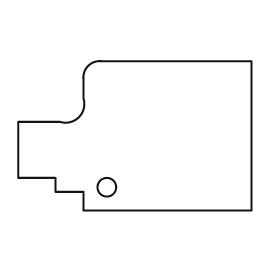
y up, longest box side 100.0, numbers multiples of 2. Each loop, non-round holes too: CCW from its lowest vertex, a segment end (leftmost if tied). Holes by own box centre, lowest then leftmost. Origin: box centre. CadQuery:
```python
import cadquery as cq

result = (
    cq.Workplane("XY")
    .moveTo(-22.0, -32.0)
    .lineTo(50.0, -32.0)
    .lineTo(50.0, 32.0)
    .lineTo(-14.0, 32.0)
    .threePointArc((-20.0, 30.0), (-22.0, 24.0))
    .lineTo(-22.0, 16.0)
    .threePointArc((-24.0, 8.0), (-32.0, 6.0))
    .lineTo(-50.0, 6.0)
    .lineTo(-50.0, -18.0)
    .lineTo(-34.0, -18.0)
    .lineTo(-34.0, -24.0)
    .lineTo(-22.0, -24.0)
    .close()
    .moveTo(-12.0, -22.0)
    .circle(4.0)
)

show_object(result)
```